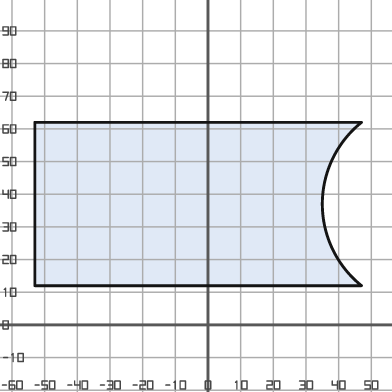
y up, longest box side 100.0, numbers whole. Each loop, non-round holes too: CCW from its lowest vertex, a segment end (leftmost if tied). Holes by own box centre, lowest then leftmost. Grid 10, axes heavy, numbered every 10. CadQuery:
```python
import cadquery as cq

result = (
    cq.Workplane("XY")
    .moveTo(-53.0, 12.0)
    .lineTo(47.0, 12.0)
    .threePointArc((35.0, 37.0), (47.0, 62.0))
    .lineTo(-53.0, 62.0)
    .close()
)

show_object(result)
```